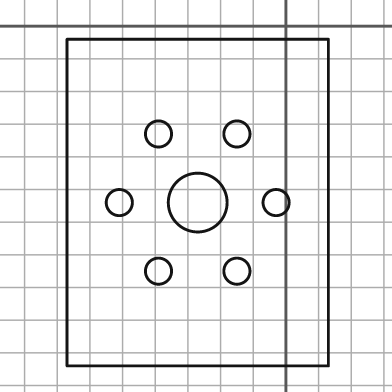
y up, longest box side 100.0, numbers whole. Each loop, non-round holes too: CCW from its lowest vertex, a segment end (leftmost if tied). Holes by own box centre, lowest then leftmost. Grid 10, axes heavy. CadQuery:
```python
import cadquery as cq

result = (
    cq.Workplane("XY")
    .moveTo(-67.0, -104.0)
    .lineTo(13.0, -104.0)
    .lineTo(13.0, -4.0)
    .lineTo(-67.0, -4.0)
    .close()
    .moveTo(-39.0, -75.0)
    .circle(4.0)
    .moveTo(-15.0, -75.0)
    .circle(4.0)
    .moveTo(-51.0, -54.0)
    .circle(4.0)
    .moveTo(-27.0, -54.0)
    .circle(9.0)
    .moveTo(-3.0, -54.0)
    .circle(4.0)
    .moveTo(-39.0, -33.0)
    .circle(4.0)
    .moveTo(-15.0, -33.0)
    .circle(4.0)
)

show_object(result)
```